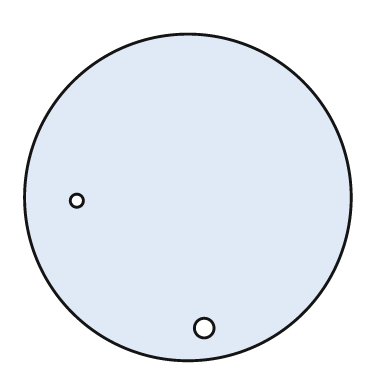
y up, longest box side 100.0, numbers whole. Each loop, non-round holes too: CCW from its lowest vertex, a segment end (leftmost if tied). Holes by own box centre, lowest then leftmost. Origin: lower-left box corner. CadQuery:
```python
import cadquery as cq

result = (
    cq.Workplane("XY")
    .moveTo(50.0, 50.0)
    .circle(50.0)
    .moveTo(55.0, 10.0)
    .circle(3.0)
    .moveTo(16.0, 49.0)
    .circle(2.0)
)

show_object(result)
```